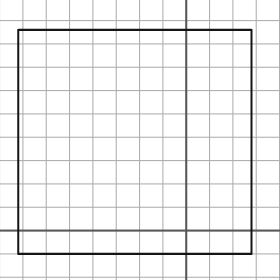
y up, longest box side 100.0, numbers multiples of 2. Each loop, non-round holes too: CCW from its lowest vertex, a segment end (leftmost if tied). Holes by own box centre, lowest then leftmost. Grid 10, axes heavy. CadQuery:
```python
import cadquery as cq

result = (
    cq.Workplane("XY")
    .moveTo(-72.0, -10.0)
    .lineTo(28.0, -10.0)
    .lineTo(28.0, 86.0)
    .lineTo(-72.0, 86.0)
    .close()
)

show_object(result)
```